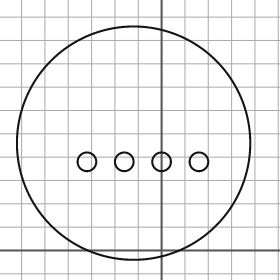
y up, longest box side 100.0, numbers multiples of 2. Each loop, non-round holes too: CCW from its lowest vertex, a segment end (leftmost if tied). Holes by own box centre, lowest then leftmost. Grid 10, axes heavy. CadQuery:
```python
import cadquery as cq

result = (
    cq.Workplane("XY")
    .moveTo(-12.0, 46.0)
    .circle(50.0)
    .moveTo(-32.0, 38.0)
    .circle(4.0)
    .moveTo(-16.0, 38.0)
    .circle(4.0)
    .moveTo(0.0, 38.0)
    .circle(4.0)
    .moveTo(16.0, 38.0)
    .circle(4.0)
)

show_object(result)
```